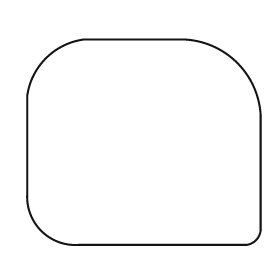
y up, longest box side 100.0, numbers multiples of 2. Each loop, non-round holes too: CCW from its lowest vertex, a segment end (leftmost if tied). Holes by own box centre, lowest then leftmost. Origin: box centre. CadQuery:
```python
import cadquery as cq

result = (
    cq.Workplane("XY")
    .moveTo(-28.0, -44.0)
    .lineTo(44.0, -44.0)
    .threePointArc((48.0, -42.0), (50.0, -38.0))
    .lineTo(50.0, 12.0)
    .threePointArc((40.0, 34.0), (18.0, 44.0))
    .lineTo(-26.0, 44.0)
    .threePointArc((-42.0, 36.0), (-50.0, 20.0))
    .lineTo(-50.0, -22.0)
    .threePointArc((-44.0, -38.0), (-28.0, -44.0))
    .close()
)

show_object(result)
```